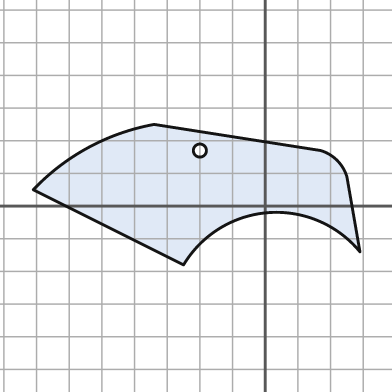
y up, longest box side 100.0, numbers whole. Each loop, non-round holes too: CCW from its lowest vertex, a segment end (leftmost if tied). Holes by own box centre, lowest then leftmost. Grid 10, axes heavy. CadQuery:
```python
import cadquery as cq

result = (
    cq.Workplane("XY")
    .moveTo(-25.0, -18.0)
    .threePointArc((1.0, -2.0), (29.0, -14.0))
    .lineTo(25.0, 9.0)
    .threePointArc((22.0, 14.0), (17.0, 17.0))
    .lineTo(-34.0, 25.0)
    .threePointArc((-54.0, 18.0), (-71.0, 5.0))
    .close()
    .moveTo(-20.0, 17.0)
    .circle(2.0)
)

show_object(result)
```